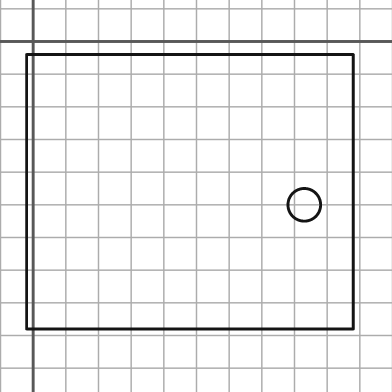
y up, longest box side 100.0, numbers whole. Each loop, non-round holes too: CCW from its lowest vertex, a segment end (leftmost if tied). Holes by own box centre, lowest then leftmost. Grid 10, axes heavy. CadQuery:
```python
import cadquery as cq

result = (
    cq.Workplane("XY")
    .moveTo(-2.0, -88.0)
    .lineTo(98.0, -88.0)
    .lineTo(98.0, -4.0)
    .lineTo(-2.0, -4.0)
    .close()
    .moveTo(83.0, -50.0)
    .circle(5.0)
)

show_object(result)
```